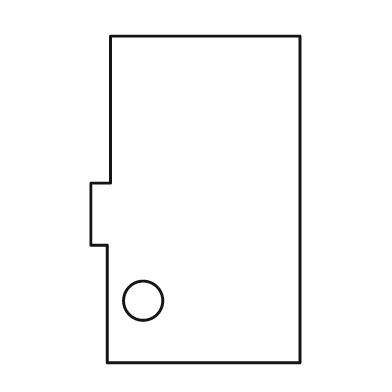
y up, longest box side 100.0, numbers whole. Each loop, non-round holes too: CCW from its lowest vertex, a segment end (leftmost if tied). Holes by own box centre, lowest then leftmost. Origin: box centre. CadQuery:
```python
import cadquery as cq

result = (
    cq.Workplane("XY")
    .moveTo(-27.0, -50.0)
    .lineTo(32.0, -50.0)
    .lineTo(32.0, 50.0)
    .lineTo(-26.0, 50.0)
    .lineTo(-26.0, 5.0)
    .lineTo(-32.0, 5.0)
    .lineTo(-32.0, -14.0)
    .lineTo(-27.0, -14.0)
    .close()
    .moveTo(-16.0, -31.0)
    .circle(6.0)
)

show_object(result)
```